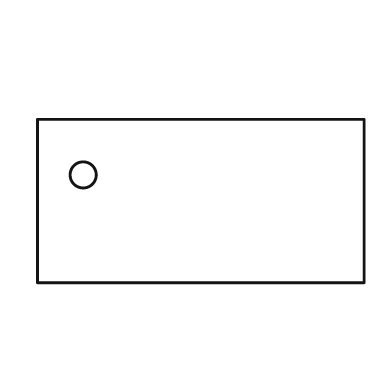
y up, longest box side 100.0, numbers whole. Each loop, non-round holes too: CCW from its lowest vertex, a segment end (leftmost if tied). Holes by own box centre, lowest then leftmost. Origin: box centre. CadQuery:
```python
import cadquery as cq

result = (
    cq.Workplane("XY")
    .moveTo(-50.0, -25.0)
    .lineTo(50.0, -25.0)
    .lineTo(50.0, 25.0)
    .lineTo(-50.0, 25.0)
    .close()
    .moveTo(-36.0, 8.0)
    .circle(4.0)
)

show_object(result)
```